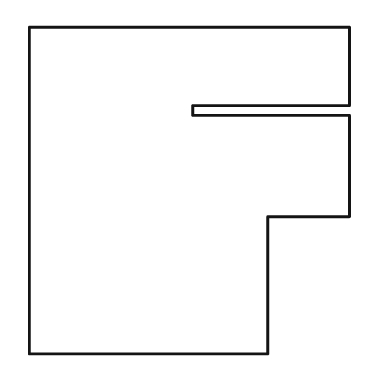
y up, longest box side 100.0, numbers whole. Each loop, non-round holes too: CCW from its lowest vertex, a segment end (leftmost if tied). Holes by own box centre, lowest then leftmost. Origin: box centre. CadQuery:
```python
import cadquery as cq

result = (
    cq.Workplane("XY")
    .moveTo(-49.0, -50.0)
    .lineTo(24.0, -50.0)
    .lineTo(24.0, -8.0)
    .lineTo(49.0, -8.0)
    .lineTo(49.0, 23.0)
    .lineTo(1.0, 23.0)
    .lineTo(1.0, 26.0)
    .lineTo(49.0, 26.0)
    .lineTo(49.0, 50.0)
    .lineTo(-49.0, 50.0)
    .close()
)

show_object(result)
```